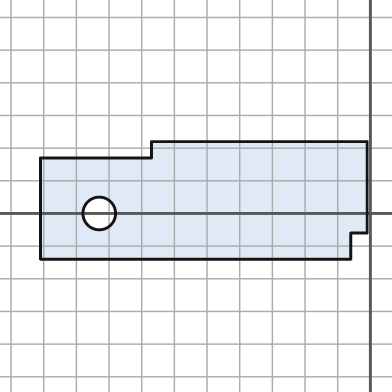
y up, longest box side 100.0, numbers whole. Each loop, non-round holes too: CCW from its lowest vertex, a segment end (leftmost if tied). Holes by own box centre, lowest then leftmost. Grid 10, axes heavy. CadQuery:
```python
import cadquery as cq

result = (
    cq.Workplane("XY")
    .moveTo(-101.0, -14.0)
    .lineTo(-6.0, -14.0)
    .lineTo(-6.0, -6.0)
    .lineTo(-1.0, -6.0)
    .lineTo(-1.0, 22.0)
    .lineTo(-67.0, 22.0)
    .lineTo(-67.0, 17.0)
    .lineTo(-101.0, 17.0)
    .close()
    .moveTo(-83.0, 0.0)
    .circle(5.0)
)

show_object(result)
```